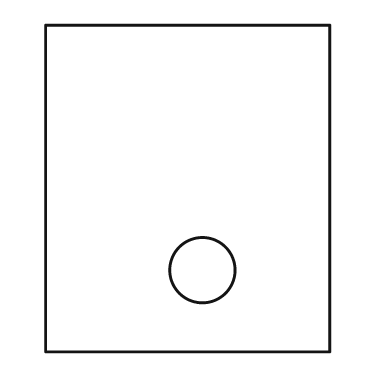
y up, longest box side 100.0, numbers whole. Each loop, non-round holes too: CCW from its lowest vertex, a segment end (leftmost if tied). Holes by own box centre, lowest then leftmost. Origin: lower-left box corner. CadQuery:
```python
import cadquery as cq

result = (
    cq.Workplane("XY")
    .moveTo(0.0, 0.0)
    .lineTo(87.0, 0.0)
    .lineTo(87.0, 100.0)
    .lineTo(0.0, 100.0)
    .close()
    .moveTo(48.0, 25.0)
    .circle(10.0)
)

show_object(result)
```